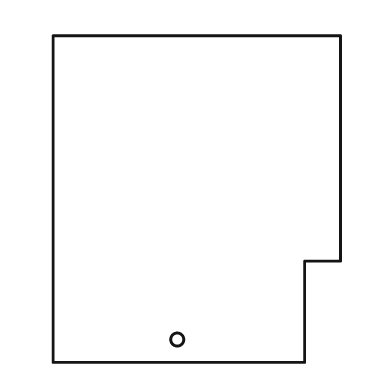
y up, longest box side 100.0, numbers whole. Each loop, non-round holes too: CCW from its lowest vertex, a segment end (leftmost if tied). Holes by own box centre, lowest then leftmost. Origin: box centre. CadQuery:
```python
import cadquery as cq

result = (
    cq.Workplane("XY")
    .moveTo(-44.0, -50.0)
    .lineTo(33.0, -50.0)
    .lineTo(33.0, -19.0)
    .lineTo(44.0, -19.0)
    .lineTo(44.0, 50.0)
    .lineTo(-44.0, 50.0)
    .close()
    .moveTo(-6.0, -43.0)
    .circle(2.0)
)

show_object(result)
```